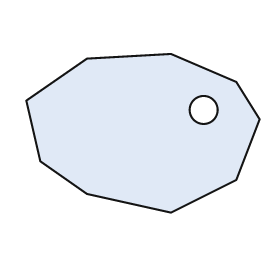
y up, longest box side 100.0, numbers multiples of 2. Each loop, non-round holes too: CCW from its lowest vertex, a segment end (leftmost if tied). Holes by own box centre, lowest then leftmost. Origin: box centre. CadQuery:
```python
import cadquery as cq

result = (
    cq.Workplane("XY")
    .moveTo(12.0, -34.0)
    .lineTo(40.0, -20.0)
    .lineTo(50.0, 6.0)
    .lineTo(40.0, 22.0)
    .lineTo(12.0, 34.0)
    .lineTo(-24.0, 32.0)
    .lineTo(-50.0, 14.0)
    .lineTo(-44.0, -12.0)
    .lineTo(-24.0, -26.0)
    .close()
    .moveTo(26.0, 10.0)
    .circle(6.0)
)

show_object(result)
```